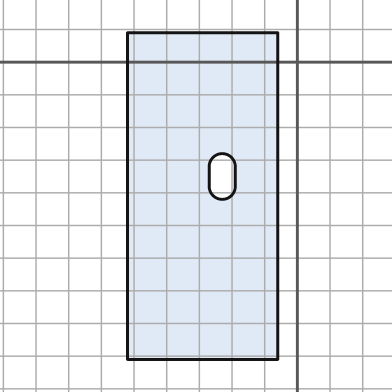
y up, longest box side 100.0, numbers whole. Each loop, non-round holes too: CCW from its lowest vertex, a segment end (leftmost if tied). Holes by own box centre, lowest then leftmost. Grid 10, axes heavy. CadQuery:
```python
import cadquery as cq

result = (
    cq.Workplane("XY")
    .moveTo(-52.0, -91.0)
    .lineTo(-6.0, -91.0)
    .lineTo(-6.0, 9.0)
    .lineTo(-52.0, 9.0)
    .close()
    .moveTo(-27.0, -38.0)
    .threePointArc((-23.0, -42.0), (-19.0, -38.0))
    .lineTo(-19.0, -32.0)
    .threePointArc((-23.0, -28.0), (-27.0, -32.0))
    .close()
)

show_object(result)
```